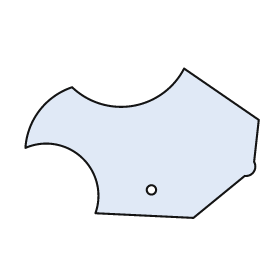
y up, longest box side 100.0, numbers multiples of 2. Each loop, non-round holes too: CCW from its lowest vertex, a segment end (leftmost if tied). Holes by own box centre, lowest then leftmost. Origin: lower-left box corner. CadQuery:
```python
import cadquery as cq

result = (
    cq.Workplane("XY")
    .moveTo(72.0, 0.0)
    .lineTo(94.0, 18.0)
    .threePointArc((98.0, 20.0), (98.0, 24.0))
    .lineTo(100.0, 42.0)
    .lineTo(68.0, 64.0)
    .threePointArc((46.0, 48.0), (20.0, 56.0))
    .threePointArc((6.0, 46.0), (0.0, 30.0))
    .threePointArc((24.0, 26.0), (30.0, 2.0))
    .close()
    .moveTo(54.0, 12.0)
    .circle(2.0)
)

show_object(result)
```